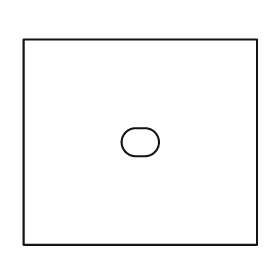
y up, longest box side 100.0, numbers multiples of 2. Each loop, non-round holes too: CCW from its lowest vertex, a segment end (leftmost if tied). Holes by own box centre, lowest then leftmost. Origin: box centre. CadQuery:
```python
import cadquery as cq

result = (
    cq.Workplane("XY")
    .moveTo(-50.0, -44.0)
    .lineTo(50.0, -44.0)
    .lineTo(50.0, 44.0)
    .lineTo(-50.0, 44.0)
    .close()
    .moveTo(-2.0, -6.0)
    .lineTo(2.0, -6.0)
    .threePointArc((8.0, 0.0), (2.0, 6.0))
    .lineTo(-2.0, 6.0)
    .threePointArc((-8.0, 0.0), (-2.0, -6.0))
    .close()
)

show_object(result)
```